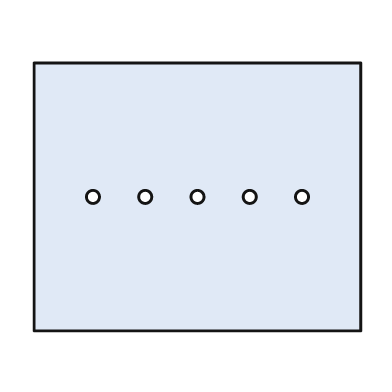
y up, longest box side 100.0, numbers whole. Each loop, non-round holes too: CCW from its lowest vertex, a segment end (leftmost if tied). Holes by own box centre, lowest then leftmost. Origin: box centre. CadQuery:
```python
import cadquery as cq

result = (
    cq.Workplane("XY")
    .moveTo(-50.0, -41.0)
    .lineTo(50.0, -41.0)
    .lineTo(50.0, 41.0)
    .lineTo(-50.0, 41.0)
    .close()
    .moveTo(-32.0, 0.0)
    .circle(2.0)
    .moveTo(-16.0, 0.0)
    .circle(2.0)
    .moveTo(0.0, 0.0)
    .circle(2.0)
    .moveTo(16.0, 0.0)
    .circle(2.0)
    .moveTo(32.0, 0.0)
    .circle(2.0)
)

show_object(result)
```